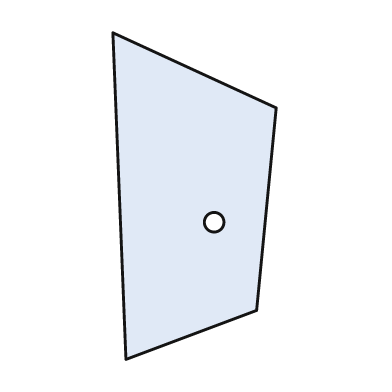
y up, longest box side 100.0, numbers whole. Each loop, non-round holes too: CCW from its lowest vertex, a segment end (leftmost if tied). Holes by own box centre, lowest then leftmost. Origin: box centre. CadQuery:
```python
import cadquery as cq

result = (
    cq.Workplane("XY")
    .moveTo(-21.0, -50.0)
    .lineTo(19.0, -35.0)
    .lineTo(25.0, 27.0)
    .lineTo(-25.0, 50.0)
    .close()
    .moveTo(6.0, -8.0)
    .circle(3.0)
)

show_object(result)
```